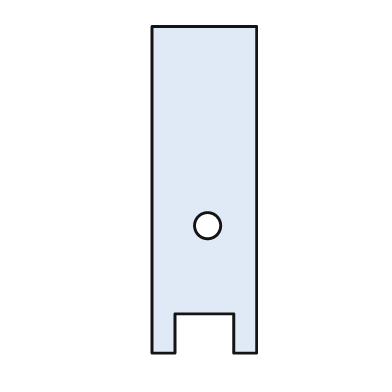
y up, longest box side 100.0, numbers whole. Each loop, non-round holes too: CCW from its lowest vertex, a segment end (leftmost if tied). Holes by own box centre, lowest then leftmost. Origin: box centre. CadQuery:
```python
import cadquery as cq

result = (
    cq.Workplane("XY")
    .moveTo(-16.0, -50.0)
    .lineTo(-9.0, -50.0)
    .lineTo(-9.0, -38.0)
    .lineTo(9.0, -38.0)
    .lineTo(9.0, -50.0)
    .lineTo(16.0, -50.0)
    .lineTo(16.0, 50.0)
    .lineTo(-16.0, 50.0)
    .close()
    .moveTo(1.0, -11.0)
    .circle(4.0)
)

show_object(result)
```